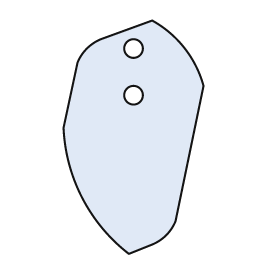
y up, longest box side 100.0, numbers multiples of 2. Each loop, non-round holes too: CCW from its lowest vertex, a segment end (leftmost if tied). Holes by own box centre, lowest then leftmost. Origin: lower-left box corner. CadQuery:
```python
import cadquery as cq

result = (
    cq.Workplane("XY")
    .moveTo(28.0, 0.0)
    .lineTo(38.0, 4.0)
    .threePointArc((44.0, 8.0), (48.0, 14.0))
    .lineTo(60.0, 72.0)
    .threePointArc((52.0, 88.0), (38.0, 100.0))
    .lineTo(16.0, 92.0)
    .threePointArc((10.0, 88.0), (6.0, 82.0))
    .lineTo(0.0, 54.0)
    .threePointArc((8.0, 24.0), (28.0, 0.0))
    .close()
    .moveTo(30.0, 68.0)
    .circle(4.0)
    .moveTo(30.0, 88.0)
    .circle(4.0)
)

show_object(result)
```